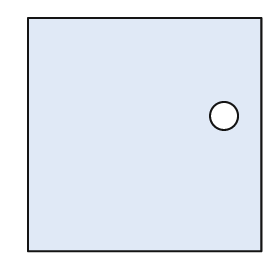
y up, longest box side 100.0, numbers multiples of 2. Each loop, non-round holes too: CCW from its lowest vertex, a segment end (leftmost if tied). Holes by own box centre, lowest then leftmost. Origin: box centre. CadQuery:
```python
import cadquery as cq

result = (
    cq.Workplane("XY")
    .moveTo(-50.0, -50.0)
    .lineTo(50.0, -50.0)
    .lineTo(50.0, 50.0)
    .lineTo(-50.0, 50.0)
    .close()
    .moveTo(34.0, 8.0)
    .circle(6.0)
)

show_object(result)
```